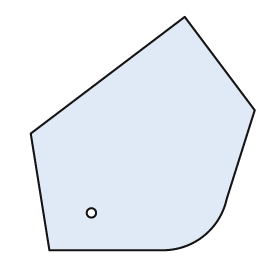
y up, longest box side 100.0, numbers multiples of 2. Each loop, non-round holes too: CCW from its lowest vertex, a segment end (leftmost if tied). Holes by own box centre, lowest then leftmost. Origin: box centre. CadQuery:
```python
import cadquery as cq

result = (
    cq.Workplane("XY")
    .moveTo(-40.0, -50.0)
    .lineTo(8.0, -50.0)
    .threePointArc((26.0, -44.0), (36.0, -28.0))
    .lineTo(48.0, 10.0)
    .lineTo(18.0, 50.0)
    .lineTo(-48.0, 0.0)
    .close()
    .moveTo(-22.0, -34.0)
    .circle(2.0)
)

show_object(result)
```